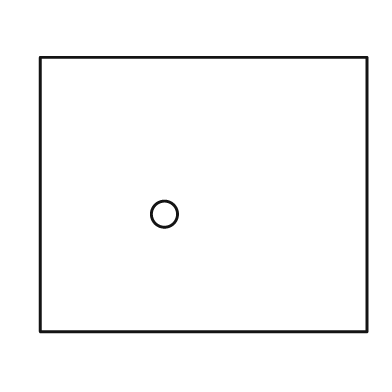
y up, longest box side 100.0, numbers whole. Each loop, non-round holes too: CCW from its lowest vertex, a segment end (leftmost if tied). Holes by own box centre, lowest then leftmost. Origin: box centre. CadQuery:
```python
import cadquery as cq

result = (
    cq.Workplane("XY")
    .moveTo(-50.0, -42.0)
    .lineTo(50.0, -42.0)
    .lineTo(50.0, 42.0)
    .lineTo(-50.0, 42.0)
    .close()
    .moveTo(-12.0, -6.0)
    .circle(4.0)
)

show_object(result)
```